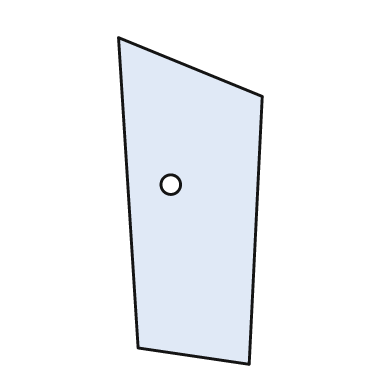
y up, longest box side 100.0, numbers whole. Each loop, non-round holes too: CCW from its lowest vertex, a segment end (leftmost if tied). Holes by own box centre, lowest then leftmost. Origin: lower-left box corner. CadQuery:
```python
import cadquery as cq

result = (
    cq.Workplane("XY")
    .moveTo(40.0, 0.0)
    .lineTo(44.0, 82.0)
    .lineTo(0.0, 100.0)
    .lineTo(6.0, 5.0)
    .close()
    .moveTo(16.0, 55.0)
    .circle(3.0)
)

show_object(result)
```